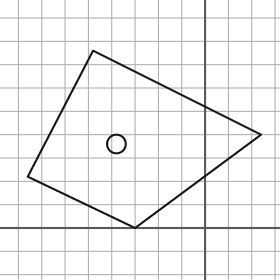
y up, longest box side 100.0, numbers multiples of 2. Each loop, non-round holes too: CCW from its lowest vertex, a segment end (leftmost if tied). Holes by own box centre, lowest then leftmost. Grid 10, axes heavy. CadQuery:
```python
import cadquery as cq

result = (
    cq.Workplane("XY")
    .moveTo(-30.0, 0.0)
    .lineTo(24.0, 40.0)
    .lineTo(-48.0, 76.0)
    .lineTo(-76.0, 22.0)
    .close()
    .moveTo(-38.0, 36.0)
    .circle(4.0)
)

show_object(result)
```